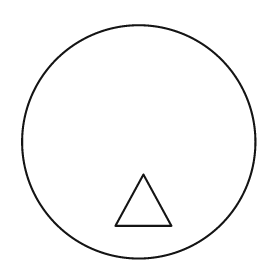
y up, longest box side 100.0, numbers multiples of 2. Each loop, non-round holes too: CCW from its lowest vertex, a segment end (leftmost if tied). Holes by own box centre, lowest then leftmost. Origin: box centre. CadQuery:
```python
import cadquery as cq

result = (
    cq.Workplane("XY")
    .moveTo(0.0, 0.0)
    .circle(50.0)
    .moveTo(-10.0, -36.0)
    .lineTo(14.0, -36.0)
    .lineTo(2.0, -14.0)
    .close()
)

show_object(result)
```